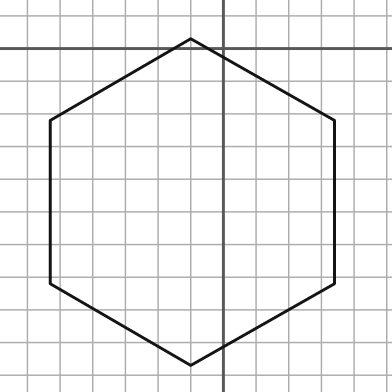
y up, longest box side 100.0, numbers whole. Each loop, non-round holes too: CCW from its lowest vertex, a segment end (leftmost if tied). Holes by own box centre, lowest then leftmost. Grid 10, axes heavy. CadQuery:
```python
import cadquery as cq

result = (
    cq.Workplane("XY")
    .moveTo(-10.0, -97.0)
    .lineTo(34.0, -72.0)
    .lineTo(34.0, -22.0)
    .lineTo(-10.0, 3.0)
    .lineTo(-53.0, -22.0)
    .lineTo(-53.0, -72.0)
    .close()
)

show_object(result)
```